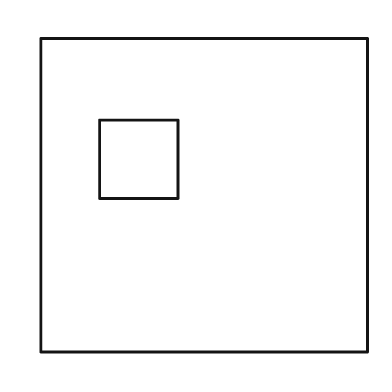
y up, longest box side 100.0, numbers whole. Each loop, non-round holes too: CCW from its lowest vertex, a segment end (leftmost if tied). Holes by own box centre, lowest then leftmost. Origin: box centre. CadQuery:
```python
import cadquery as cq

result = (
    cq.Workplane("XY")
    .moveTo(-50.0, -48.0)
    .lineTo(50.0, -48.0)
    .lineTo(50.0, 48.0)
    .lineTo(-50.0, 48.0)
    .close()
    .moveTo(-32.0, -1.0)
    .lineTo(-8.0, -1.0)
    .lineTo(-8.0, 23.0)
    .lineTo(-32.0, 23.0)
    .close()
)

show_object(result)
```